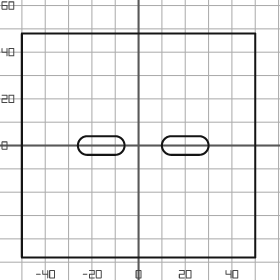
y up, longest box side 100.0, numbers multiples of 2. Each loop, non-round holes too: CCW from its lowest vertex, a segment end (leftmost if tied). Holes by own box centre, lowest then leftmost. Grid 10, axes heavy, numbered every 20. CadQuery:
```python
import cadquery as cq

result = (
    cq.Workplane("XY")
    .moveTo(-50.0, -48.0)
    .lineTo(50.0, -48.0)
    .lineTo(50.0, 48.0)
    .lineTo(-50.0, 48.0)
    .close()
    .moveTo(-22.0, -4.0)
    .lineTo(-10.0, -4.0)
    .threePointArc((-6.0, 0.0), (-10.0, 4.0))
    .lineTo(-22.0, 4.0)
    .threePointArc((-26.0, 0.0), (-22.0, -4.0))
    .close()
    .moveTo(14.0, -4.0)
    .lineTo(26.0, -4.0)
    .threePointArc((30.0, 0.0), (26.0, 4.0))
    .lineTo(14.0, 4.0)
    .threePointArc((10.0, 0.0), (14.0, -4.0))
    .close()
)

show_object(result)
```